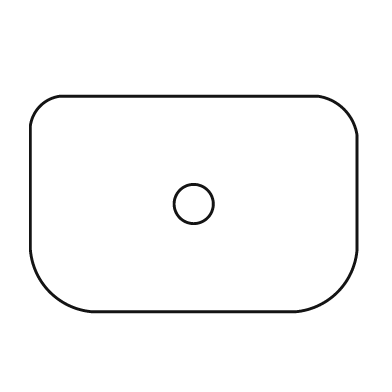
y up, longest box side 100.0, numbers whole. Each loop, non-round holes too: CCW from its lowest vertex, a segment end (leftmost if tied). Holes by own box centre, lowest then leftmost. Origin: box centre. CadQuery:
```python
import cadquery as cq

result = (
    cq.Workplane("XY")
    .moveTo(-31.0, -33.0)
    .lineTo(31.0, -33.0)
    .threePointArc((44.0, -27.0), (50.0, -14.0))
    .lineTo(50.0, 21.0)
    .threePointArc((46.0, 29.0), (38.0, 33.0))
    .lineTo(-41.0, 33.0)
    .threePointArc((-47.0, 30.0), (-50.0, 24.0))
    .lineTo(-50.0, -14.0)
    .threePointArc((-44.0, -27.0), (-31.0, -33.0))
    .close()
    .moveTo(0.0, 0.0)
    .circle(6.0)
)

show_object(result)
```